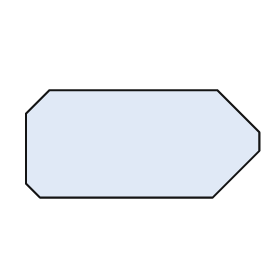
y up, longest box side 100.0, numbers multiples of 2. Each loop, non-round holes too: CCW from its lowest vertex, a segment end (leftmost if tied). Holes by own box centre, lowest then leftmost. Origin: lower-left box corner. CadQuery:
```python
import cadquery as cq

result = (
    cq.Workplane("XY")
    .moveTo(6.0, 0.0)
    .lineTo(80.0, 0.0)
    .lineTo(100.0, 20.0)
    .lineTo(100.0, 28.0)
    .lineTo(82.0, 46.0)
    .lineTo(10.0, 46.0)
    .lineTo(0.0, 36.0)
    .lineTo(0.0, 6.0)
    .close()
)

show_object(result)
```